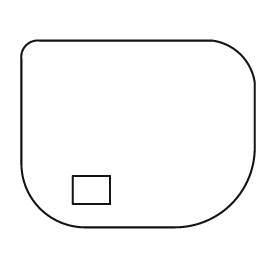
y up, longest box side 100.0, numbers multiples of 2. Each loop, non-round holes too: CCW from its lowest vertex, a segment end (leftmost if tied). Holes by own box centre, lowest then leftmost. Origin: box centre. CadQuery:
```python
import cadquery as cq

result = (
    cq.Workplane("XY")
    .moveTo(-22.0, -40.0)
    .lineTo(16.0, -40.0)
    .threePointArc((40.0, -30.0), (50.0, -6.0))
    .lineTo(50.0, 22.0)
    .threePointArc((44.0, 34.0), (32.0, 40.0))
    .lineTo(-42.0, 40.0)
    .threePointArc((-48.0, 38.0), (-50.0, 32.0))
    .lineTo(-50.0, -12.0)
    .threePointArc((-42.0, -32.0), (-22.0, -40.0))
    .close()
    .moveTo(-28.0, -30.0)
    .lineTo(-12.0, -30.0)
    .lineTo(-12.0, -18.0)
    .lineTo(-28.0, -18.0)
    .close()
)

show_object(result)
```